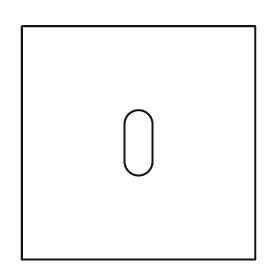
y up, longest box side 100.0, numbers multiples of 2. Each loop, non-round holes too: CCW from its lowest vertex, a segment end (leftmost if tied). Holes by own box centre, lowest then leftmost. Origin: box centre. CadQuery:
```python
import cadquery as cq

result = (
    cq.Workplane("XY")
    .moveTo(-50.0, -50.0)
    .lineTo(50.0, -50.0)
    .lineTo(50.0, 50.0)
    .lineTo(-50.0, 50.0)
    .close()
    .moveTo(-6.0, -8.0)
    .threePointArc((0.0, -14.0), (6.0, -8.0))
    .lineTo(6.0, 8.0)
    .threePointArc((0.0, 14.0), (-6.0, 8.0))
    .close()
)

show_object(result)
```